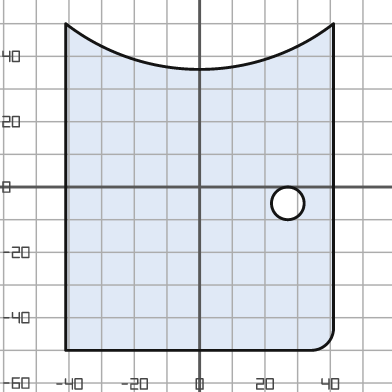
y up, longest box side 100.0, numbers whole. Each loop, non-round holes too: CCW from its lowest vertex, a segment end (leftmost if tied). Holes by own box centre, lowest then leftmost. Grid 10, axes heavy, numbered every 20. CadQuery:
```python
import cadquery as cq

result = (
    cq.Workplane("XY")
    .moveTo(-41.0, -50.0)
    .lineTo(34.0, -50.0)
    .threePointArc((39.0, -48.0), (41.0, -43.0))
    .lineTo(41.0, 50.0)
    .threePointArc((0.0, 36.0), (-41.0, 50.0))
    .close()
    .moveTo(27.0, -5.0)
    .circle(5.0)
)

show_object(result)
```